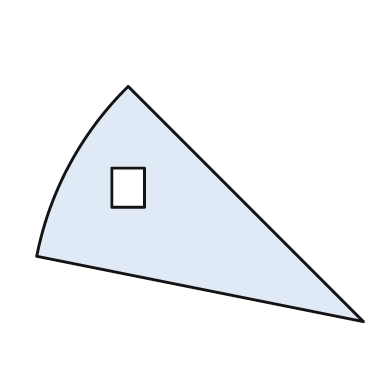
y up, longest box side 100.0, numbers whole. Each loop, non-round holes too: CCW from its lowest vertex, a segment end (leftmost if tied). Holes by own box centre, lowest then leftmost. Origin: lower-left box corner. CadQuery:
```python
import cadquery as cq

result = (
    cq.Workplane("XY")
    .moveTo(100.0, 0.0)
    .lineTo(28.0, 72.0)
    .threePointArc((10.0, 48.0), (0.0, 20.0))
    .close()
    .moveTo(23.0, 35.0)
    .lineTo(33.0, 35.0)
    .lineTo(33.0, 47.0)
    .lineTo(23.0, 47.0)
    .close()
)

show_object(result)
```